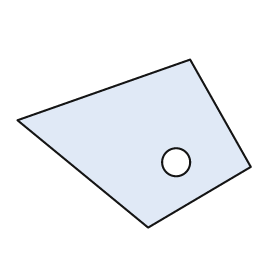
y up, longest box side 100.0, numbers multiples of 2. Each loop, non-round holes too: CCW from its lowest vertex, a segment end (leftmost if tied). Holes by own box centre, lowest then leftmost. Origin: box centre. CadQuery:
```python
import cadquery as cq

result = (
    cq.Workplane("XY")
    .moveTo(6.0, -36.0)
    .lineTo(50.0, -10.0)
    .lineTo(24.0, 36.0)
    .lineTo(-50.0, 10.0)
    .close()
    .moveTo(18.0, -8.0)
    .circle(6.0)
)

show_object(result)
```